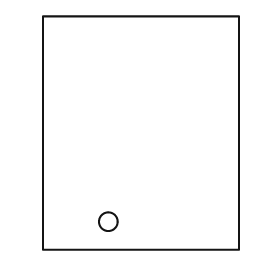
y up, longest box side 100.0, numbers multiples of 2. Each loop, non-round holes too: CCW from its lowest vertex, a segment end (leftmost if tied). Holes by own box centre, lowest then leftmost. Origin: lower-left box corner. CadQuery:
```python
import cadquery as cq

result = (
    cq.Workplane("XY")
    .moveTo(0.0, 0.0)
    .lineTo(84.0, 0.0)
    .lineTo(84.0, 100.0)
    .lineTo(0.0, 100.0)
    .close()
    .moveTo(28.0, 12.0)
    .circle(4.0)
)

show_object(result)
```